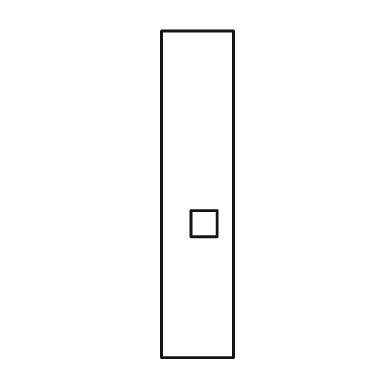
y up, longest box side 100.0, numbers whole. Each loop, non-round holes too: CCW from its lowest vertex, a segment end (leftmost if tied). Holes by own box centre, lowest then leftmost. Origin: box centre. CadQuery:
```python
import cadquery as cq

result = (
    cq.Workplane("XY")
    .moveTo(-11.0, -50.0)
    .lineTo(11.0, -50.0)
    .lineTo(11.0, 50.0)
    .lineTo(-11.0, 50.0)
    .close()
    .moveTo(-2.0, -13.0)
    .lineTo(6.0, -13.0)
    .lineTo(6.0, -5.0)
    .lineTo(-2.0, -5.0)
    .close()
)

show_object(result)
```